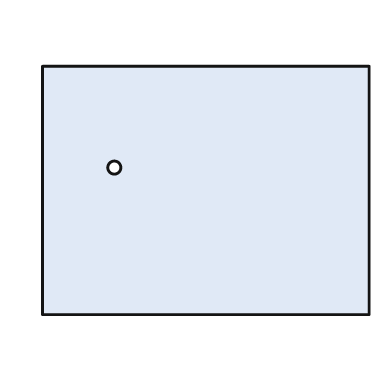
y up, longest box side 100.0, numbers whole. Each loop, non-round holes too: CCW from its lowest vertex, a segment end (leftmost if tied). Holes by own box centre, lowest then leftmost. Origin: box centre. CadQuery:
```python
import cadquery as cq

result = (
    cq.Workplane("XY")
    .moveTo(-50.0, -38.0)
    .lineTo(50.0, -38.0)
    .lineTo(50.0, 38.0)
    .lineTo(-50.0, 38.0)
    .close()
    .moveTo(-28.0, 7.0)
    .circle(2.0)
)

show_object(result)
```